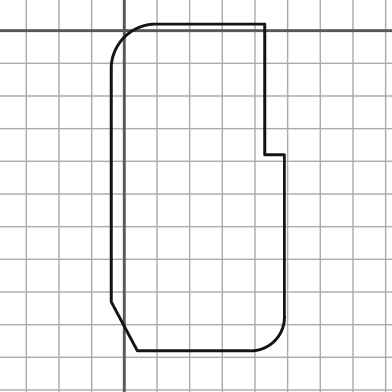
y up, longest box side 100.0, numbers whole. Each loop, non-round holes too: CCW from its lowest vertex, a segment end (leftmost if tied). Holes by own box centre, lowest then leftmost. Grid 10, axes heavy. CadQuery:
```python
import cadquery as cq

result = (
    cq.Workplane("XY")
    .moveTo(4.0, -98.0)
    .lineTo(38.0, -98.0)
    .threePointArc((46.0, -95.0), (49.0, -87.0))
    .lineTo(49.0, -38.0)
    .lineTo(43.0, -38.0)
    .lineTo(43.0, 2.0)
    .lineTo(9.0, 2.0)
    .threePointArc((0.0, -2.0), (-4.0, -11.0))
    .lineTo(-4.0, -83.0)
    .close()
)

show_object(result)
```